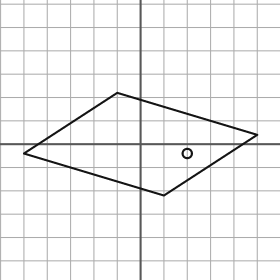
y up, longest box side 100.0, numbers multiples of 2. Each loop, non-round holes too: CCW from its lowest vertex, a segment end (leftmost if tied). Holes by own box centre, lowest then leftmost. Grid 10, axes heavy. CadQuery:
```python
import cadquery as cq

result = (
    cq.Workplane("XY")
    .moveTo(10.0, -22.0)
    .lineTo(50.0, 4.0)
    .lineTo(-10.0, 22.0)
    .lineTo(-50.0, -4.0)
    .close()
    .moveTo(20.0, -4.0)
    .circle(2.0)
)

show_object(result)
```